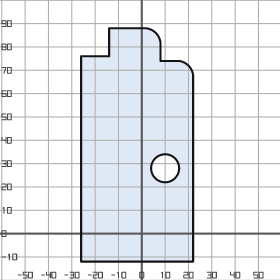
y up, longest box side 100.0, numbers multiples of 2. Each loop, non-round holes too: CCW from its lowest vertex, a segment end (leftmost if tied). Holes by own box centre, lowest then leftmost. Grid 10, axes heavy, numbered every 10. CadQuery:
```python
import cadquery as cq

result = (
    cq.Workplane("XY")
    .moveTo(-26.0, -12.0)
    .lineTo(22.0, -12.0)
    .lineTo(22.0, 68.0)
    .threePointArc((20.0, 72.0), (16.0, 74.0))
    .lineTo(8.0, 74.0)
    .lineTo(8.0, 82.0)
    .threePointArc((6.0, 86.0), (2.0, 88.0))
    .lineTo(-14.0, 88.0)
    .lineTo(-14.0, 76.0)
    .lineTo(-26.0, 76.0)
    .close()
    .moveTo(10.0, 28.0)
    .circle(6.0)
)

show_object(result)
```